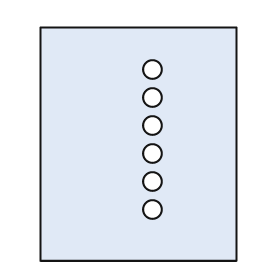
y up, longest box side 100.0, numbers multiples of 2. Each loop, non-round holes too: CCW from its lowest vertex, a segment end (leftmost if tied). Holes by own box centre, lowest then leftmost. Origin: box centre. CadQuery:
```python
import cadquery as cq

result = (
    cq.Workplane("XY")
    .moveTo(-42.0, -50.0)
    .lineTo(42.0, -50.0)
    .lineTo(42.0, 50.0)
    .lineTo(-42.0, 50.0)
    .close()
    .moveTo(6.0, -28.0)
    .circle(4.0)
    .moveTo(6.0, -16.0)
    .circle(4.0)
    .moveTo(6.0, -4.0)
    .circle(4.0)
    .moveTo(6.0, 8.0)
    .circle(4.0)
    .moveTo(6.0, 20.0)
    .circle(4.0)
    .moveTo(6.0, 32.0)
    .circle(4.0)
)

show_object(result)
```